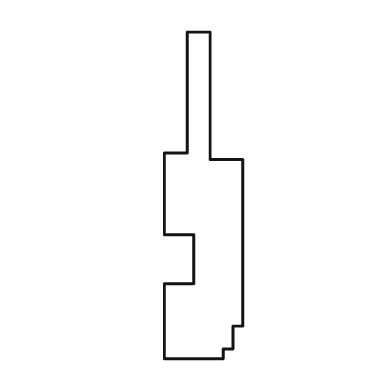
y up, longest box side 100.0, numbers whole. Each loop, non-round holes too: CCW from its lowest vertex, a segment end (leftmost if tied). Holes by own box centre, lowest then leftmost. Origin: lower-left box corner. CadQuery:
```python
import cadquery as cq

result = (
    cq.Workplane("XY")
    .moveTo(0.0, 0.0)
    .lineTo(18.0, 0.0)
    .lineTo(18.0, 3.0)
    .lineTo(21.0, 3.0)
    .lineTo(21.0, 10.0)
    .lineTo(24.0, 10.0)
    .lineTo(24.0, 61.0)
    .lineTo(14.0, 61.0)
    .lineTo(14.0, 100.0)
    .lineTo(7.0, 100.0)
    .lineTo(7.0, 63.0)
    .lineTo(0.0, 63.0)
    .lineTo(0.0, 38.0)
    .lineTo(9.0, 38.0)
    .lineTo(9.0, 23.0)
    .lineTo(0.0, 23.0)
    .close()
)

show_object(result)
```